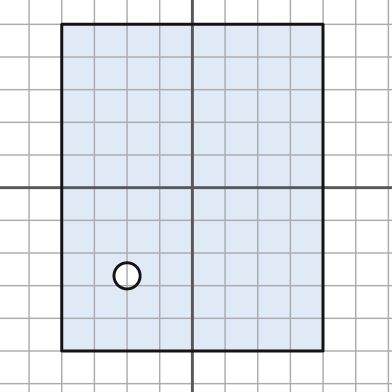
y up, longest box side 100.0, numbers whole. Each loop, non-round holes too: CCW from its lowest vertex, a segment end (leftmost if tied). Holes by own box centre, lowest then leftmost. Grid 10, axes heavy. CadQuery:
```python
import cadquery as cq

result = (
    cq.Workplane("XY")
    .moveTo(-40.0, -50.0)
    .lineTo(40.0, -50.0)
    .lineTo(40.0, 50.0)
    .lineTo(-40.0, 50.0)
    .close()
    .moveTo(-20.0, -27.0)
    .circle(4.0)
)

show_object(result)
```